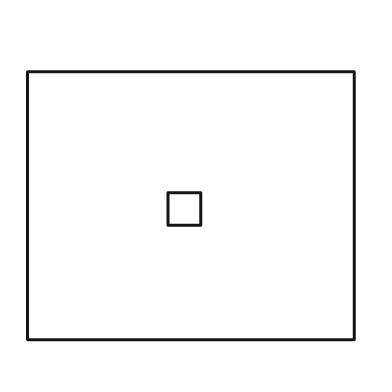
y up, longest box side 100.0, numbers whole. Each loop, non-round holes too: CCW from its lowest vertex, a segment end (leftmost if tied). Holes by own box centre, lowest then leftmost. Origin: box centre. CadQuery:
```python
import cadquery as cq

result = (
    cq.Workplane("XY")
    .moveTo(-50.0, -41.0)
    .lineTo(50.0, -41.0)
    .lineTo(50.0, 41.0)
    .lineTo(-50.0, 41.0)
    .close()
    .moveTo(-7.0, -6.0)
    .lineTo(3.0, -6.0)
    .lineTo(3.0, 4.0)
    .lineTo(-7.0, 4.0)
    .close()
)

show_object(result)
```